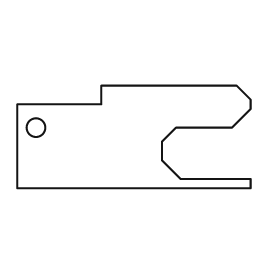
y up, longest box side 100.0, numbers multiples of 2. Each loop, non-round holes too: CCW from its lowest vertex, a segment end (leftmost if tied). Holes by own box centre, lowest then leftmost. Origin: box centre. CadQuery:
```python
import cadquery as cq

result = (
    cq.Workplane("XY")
    .moveTo(-50.0, -22.0)
    .lineTo(50.0, -22.0)
    .lineTo(50.0, -18.0)
    .lineTo(20.0, -18.0)
    .lineTo(12.0, -10.0)
    .lineTo(12.0, -2.0)
    .lineTo(18.0, 4.0)
    .lineTo(42.0, 4.0)
    .lineTo(50.0, 12.0)
    .lineTo(50.0, 16.0)
    .lineTo(44.0, 22.0)
    .lineTo(-14.0, 22.0)
    .lineTo(-14.0, 14.0)
    .lineTo(-50.0, 14.0)
    .close()
    .moveTo(-42.0, 4.0)
    .circle(4.0)
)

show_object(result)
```